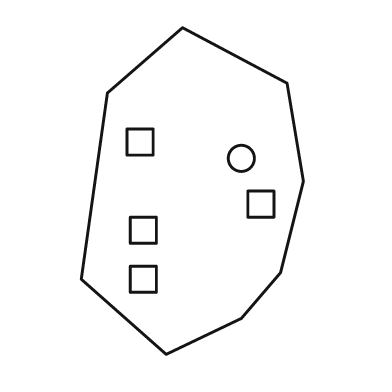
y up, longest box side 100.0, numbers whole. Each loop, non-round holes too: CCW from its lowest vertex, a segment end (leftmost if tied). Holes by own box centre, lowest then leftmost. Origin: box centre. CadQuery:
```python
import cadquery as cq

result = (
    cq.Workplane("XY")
    .moveTo(-8.0, -50.0)
    .lineTo(15.0, -39.0)
    .lineTo(27.0, -25.0)
    .lineTo(34.0, 3.0)
    .lineTo(29.0, 33.0)
    .lineTo(-3.0, 50.0)
    .lineTo(-26.0, 30.0)
    .lineTo(-34.0, -27.0)
    .close()
    .moveTo(-19.0, -31.0)
    .lineTo(-11.0, -31.0)
    .lineTo(-11.0, -23.0)
    .lineTo(-19.0, -23.0)
    .close()
    .moveTo(-19.0, -16.0)
    .lineTo(-11.0, -16.0)
    .lineTo(-11.0, -8.0)
    .lineTo(-19.0, -8.0)
    .close()
    .moveTo(17.0, -8.0)
    .lineTo(25.0, -8.0)
    .lineTo(25.0, 0.0)
    .lineTo(17.0, 0.0)
    .close()
    .moveTo(15.0, 10.0)
    .circle(4.0)
    .moveTo(-20.0, 11.0)
    .lineTo(-12.0, 11.0)
    .lineTo(-12.0, 19.0)
    .lineTo(-20.0, 19.0)
    .close()
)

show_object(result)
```